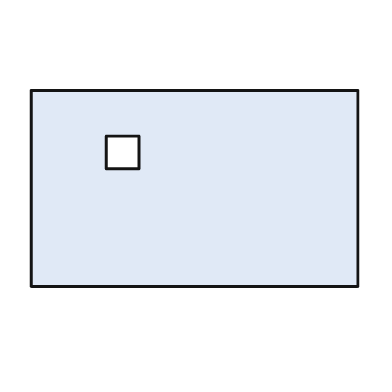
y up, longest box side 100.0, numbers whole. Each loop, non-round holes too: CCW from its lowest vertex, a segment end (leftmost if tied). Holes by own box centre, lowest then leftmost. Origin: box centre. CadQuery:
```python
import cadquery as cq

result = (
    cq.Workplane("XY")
    .moveTo(-50.0, -30.0)
    .lineTo(50.0, -30.0)
    .lineTo(50.0, 30.0)
    .lineTo(-50.0, 30.0)
    .close()
    .moveTo(-27.0, 6.0)
    .lineTo(-17.0, 6.0)
    .lineTo(-17.0, 16.0)
    .lineTo(-27.0, 16.0)
    .close()
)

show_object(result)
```